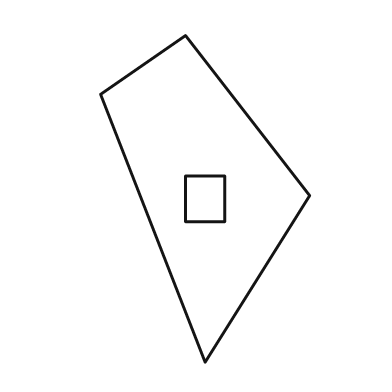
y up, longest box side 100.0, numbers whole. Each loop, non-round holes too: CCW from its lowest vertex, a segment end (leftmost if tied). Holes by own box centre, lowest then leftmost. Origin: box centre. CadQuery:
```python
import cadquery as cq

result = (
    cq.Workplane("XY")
    .moveTo(0.0, -50.0)
    .lineTo(32.0, 1.0)
    .lineTo(-6.0, 50.0)
    .lineTo(-32.0, 32.0)
    .close()
    .moveTo(-6.0, -7.0)
    .lineTo(6.0, -7.0)
    .lineTo(6.0, 7.0)
    .lineTo(-6.0, 7.0)
    .close()
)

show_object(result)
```